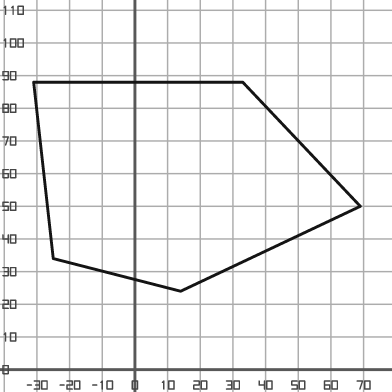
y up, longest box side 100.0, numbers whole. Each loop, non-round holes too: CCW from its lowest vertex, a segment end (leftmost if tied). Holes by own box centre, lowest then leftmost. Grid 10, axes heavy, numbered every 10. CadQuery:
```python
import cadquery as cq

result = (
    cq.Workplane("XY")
    .moveTo(14.0, 24.0)
    .lineTo(69.0, 50.0)
    .lineTo(33.0, 88.0)
    .lineTo(-31.0, 88.0)
    .lineTo(-25.0, 34.0)
    .close()
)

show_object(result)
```